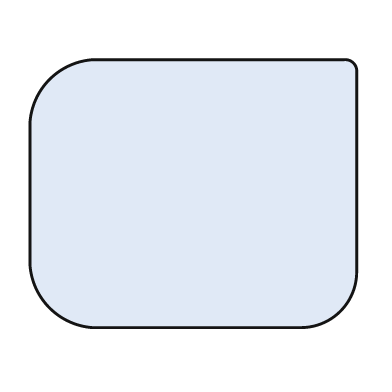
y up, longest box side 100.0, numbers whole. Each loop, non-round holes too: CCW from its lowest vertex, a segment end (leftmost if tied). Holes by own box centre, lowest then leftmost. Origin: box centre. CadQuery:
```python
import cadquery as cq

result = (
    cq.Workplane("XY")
    .moveTo(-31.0, -41.0)
    .lineTo(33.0, -41.0)
    .threePointArc((45.0, -36.0), (50.0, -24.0))
    .lineTo(50.0, 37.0)
    .threePointArc((49.0, 40.0), (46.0, 41.0))
    .lineTo(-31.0, 41.0)
    .threePointArc((-44.0, 35.0), (-50.0, 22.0))
    .lineTo(-50.0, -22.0)
    .threePointArc((-44.0, -35.0), (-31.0, -41.0))
    .close()
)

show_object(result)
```